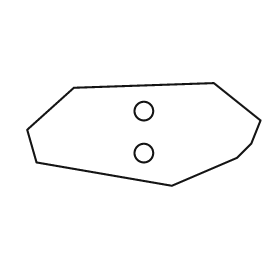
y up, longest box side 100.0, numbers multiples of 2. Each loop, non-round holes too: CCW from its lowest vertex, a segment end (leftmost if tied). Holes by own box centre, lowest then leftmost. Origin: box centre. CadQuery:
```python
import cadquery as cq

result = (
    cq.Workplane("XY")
    .moveTo(12.0, -22.0)
    .lineTo(40.0, -10.0)
    .lineTo(46.0, -4.0)
    .lineTo(50.0, 6.0)
    .lineTo(30.0, 22.0)
    .lineTo(-30.0, 20.0)
    .lineTo(-50.0, 2.0)
    .lineTo(-46.0, -12.0)
    .close()
    .moveTo(0.0, -8.0)
    .circle(4.0)
    .moveTo(0.0, 10.0)
    .circle(4.0)
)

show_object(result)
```